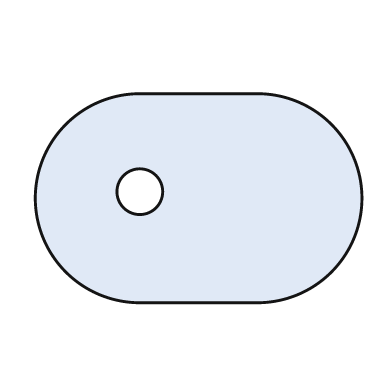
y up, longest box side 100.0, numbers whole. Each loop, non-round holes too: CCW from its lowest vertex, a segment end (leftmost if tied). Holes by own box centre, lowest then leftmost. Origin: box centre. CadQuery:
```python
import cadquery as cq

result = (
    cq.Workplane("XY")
    .moveTo(-18.0, -32.0)
    .lineTo(18.0, -32.0)
    .threePointArc((50.0, 0.0), (18.0, 32.0))
    .lineTo(-18.0, 32.0)
    .threePointArc((-50.0, 0.0), (-18.0, -32.0))
    .close()
    .moveTo(-18.0, 2.0)
    .circle(7.0)
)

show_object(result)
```